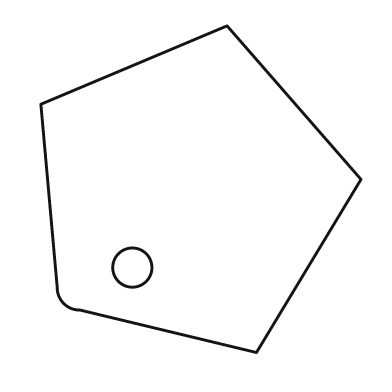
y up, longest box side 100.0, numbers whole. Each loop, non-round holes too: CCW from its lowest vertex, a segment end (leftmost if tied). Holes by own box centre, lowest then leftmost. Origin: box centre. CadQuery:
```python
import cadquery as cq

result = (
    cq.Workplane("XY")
    .moveTo(17.0, -50.0)
    .lineTo(49.0, 3.0)
    .lineTo(8.0, 50.0)
    .lineTo(-49.0, 26.0)
    .lineTo(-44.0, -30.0)
    .threePointArc((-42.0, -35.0), (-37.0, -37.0))
    .close()
    .moveTo(-21.0, -24.0)
    .circle(6.0)
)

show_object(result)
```